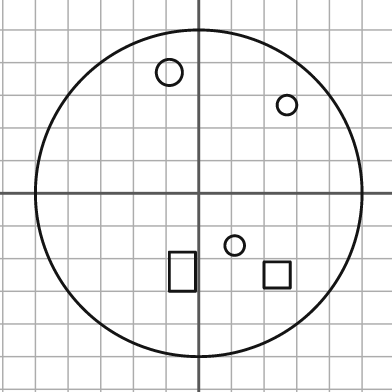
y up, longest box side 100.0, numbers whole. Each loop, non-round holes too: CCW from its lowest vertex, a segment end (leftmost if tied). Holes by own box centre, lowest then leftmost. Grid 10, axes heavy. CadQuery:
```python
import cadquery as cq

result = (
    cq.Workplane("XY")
    .moveTo(0.0, 0.0)
    .circle(50.0)
    .moveTo(20.0, -29.0)
    .lineTo(28.0, -29.0)
    .lineTo(28.0, -21.0)
    .lineTo(20.0, -21.0)
    .close()
    .moveTo(-9.0, -30.0)
    .lineTo(-1.0, -30.0)
    .lineTo(-1.0, -18.0)
    .lineTo(-9.0, -18.0)
    .close()
    .moveTo(11.0, -16.0)
    .circle(3.0)
    .moveTo(27.0, 27.0)
    .circle(3.0)
    .moveTo(-9.0, 37.0)
    .circle(4.0)
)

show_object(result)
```